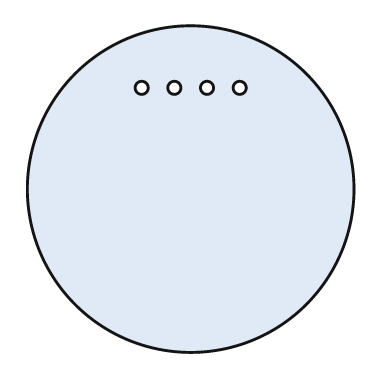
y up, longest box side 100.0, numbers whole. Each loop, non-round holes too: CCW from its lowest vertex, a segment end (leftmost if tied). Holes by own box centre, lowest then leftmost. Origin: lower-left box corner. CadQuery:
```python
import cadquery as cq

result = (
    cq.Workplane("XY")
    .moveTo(50.0, 50.0)
    .circle(50.0)
    .moveTo(35.0, 81.0)
    .circle(2.0)
    .moveTo(45.0, 81.0)
    .circle(2.0)
    .moveTo(55.0, 81.0)
    .circle(2.0)
    .moveTo(65.0, 81.0)
    .circle(2.0)
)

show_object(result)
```